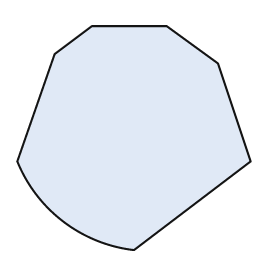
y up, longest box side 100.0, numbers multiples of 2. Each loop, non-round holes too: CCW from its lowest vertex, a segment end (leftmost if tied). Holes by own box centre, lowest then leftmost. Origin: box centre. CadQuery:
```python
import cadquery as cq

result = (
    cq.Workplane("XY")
    .moveTo(0.0, -48.0)
    .lineTo(50.0, -10.0)
    .lineTo(36.0, 32.0)
    .lineTo(14.0, 48.0)
    .lineTo(-18.0, 48.0)
    .lineTo(-34.0, 36.0)
    .lineTo(-50.0, -10.0)
    .threePointArc((-30.0, -36.0), (0.0, -48.0))
    .close()
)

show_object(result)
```